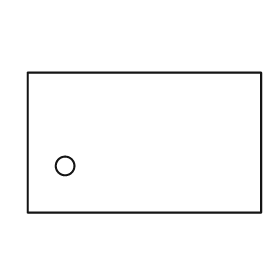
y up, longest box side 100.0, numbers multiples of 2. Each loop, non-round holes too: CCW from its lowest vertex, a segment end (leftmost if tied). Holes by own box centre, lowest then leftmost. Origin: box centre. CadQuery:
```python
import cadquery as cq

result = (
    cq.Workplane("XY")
    .moveTo(-50.0, -30.0)
    .lineTo(50.0, -30.0)
    .lineTo(50.0, 30.0)
    .lineTo(-50.0, 30.0)
    .close()
    .moveTo(-34.0, -10.0)
    .circle(4.0)
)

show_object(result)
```